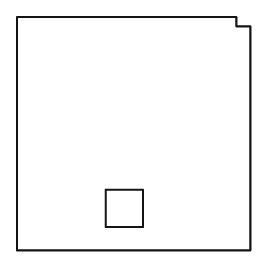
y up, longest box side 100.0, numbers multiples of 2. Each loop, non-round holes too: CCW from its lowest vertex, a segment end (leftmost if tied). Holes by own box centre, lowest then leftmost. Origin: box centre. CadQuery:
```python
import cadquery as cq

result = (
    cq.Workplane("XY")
    .moveTo(-50.0, -50.0)
    .lineTo(50.0, -50.0)
    .lineTo(50.0, 46.0)
    .lineTo(44.0, 46.0)
    .lineTo(44.0, 50.0)
    .lineTo(-50.0, 50.0)
    .close()
    .moveTo(-12.0, -40.0)
    .lineTo(4.0, -40.0)
    .lineTo(4.0, -24.0)
    .lineTo(-12.0, -24.0)
    .close()
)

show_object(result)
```